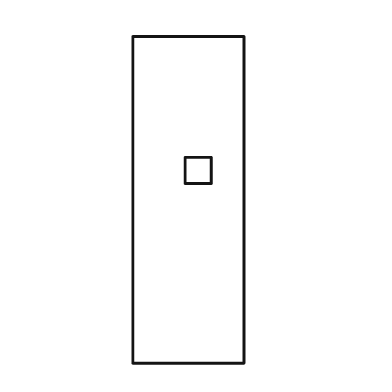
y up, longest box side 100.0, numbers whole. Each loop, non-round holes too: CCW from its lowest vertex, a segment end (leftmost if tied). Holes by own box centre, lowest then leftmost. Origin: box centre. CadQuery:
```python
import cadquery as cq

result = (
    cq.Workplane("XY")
    .moveTo(-17.0, -50.0)
    .lineTo(17.0, -50.0)
    .lineTo(17.0, 50.0)
    .lineTo(-17.0, 50.0)
    .close()
    .moveTo(-1.0, 5.0)
    .lineTo(7.0, 5.0)
    .lineTo(7.0, 13.0)
    .lineTo(-1.0, 13.0)
    .close()
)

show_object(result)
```